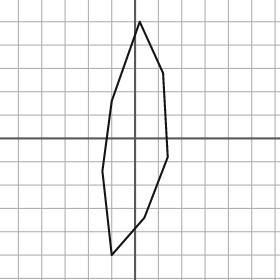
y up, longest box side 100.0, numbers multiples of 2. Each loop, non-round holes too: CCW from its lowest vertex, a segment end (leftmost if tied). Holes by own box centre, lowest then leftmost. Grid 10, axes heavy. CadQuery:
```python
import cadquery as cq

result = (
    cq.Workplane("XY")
    .moveTo(-10.0, -50.0)
    .lineTo(4.0, -34.0)
    .lineTo(14.0, -8.0)
    .lineTo(12.0, 28.0)
    .lineTo(2.0, 50.0)
    .lineTo(-10.0, 16.0)
    .lineTo(-14.0, -14.0)
    .close()
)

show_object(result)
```